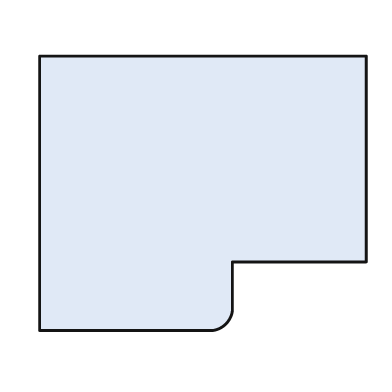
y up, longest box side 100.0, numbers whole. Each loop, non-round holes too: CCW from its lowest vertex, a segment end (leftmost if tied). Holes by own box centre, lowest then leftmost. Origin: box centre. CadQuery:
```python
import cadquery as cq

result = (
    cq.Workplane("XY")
    .moveTo(-50.0, -42.0)
    .lineTo(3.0, -42.0)
    .threePointArc((7.0, -40.0), (9.0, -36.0))
    .lineTo(9.0, -21.0)
    .lineTo(50.0, -21.0)
    .lineTo(50.0, 42.0)
    .lineTo(-50.0, 42.0)
    .close()
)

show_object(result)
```